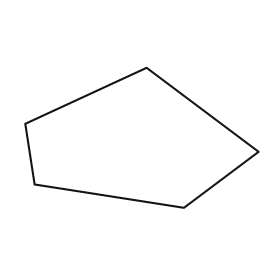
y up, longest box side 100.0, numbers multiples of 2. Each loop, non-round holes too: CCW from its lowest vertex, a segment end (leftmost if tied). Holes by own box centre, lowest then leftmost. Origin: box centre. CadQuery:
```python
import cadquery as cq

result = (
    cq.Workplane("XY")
    .moveTo(18.0, -30.0)
    .lineTo(50.0, -6.0)
    .lineTo(2.0, 30.0)
    .lineTo(-50.0, 6.0)
    .lineTo(-46.0, -20.0)
    .close()
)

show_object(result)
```